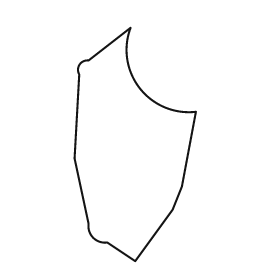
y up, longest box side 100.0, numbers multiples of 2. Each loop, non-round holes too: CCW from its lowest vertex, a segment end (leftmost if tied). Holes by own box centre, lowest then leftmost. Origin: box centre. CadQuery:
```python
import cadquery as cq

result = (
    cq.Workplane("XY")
    .moveTo(0.0, -50.0)
    .lineTo(16.0, -28.0)
    .lineTo(20.0, -18.0)
    .lineTo(26.0, 14.0)
    .threePointArc((2.0, 24.0), (-2.0, 50.0))
    .lineTo(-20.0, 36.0)
    .threePointArc((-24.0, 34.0), (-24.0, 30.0))
    .lineTo(-26.0, -6.0)
    .lineTo(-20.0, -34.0)
    .threePointArc((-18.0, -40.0), (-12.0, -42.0))
    .close()
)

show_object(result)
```